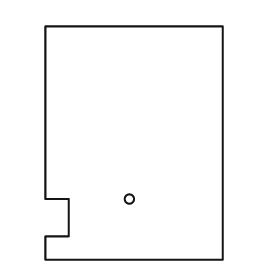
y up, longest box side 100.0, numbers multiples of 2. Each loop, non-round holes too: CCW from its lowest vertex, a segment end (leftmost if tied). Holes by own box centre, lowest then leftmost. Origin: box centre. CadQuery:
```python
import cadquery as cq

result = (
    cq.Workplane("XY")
    .moveTo(-38.0, -50.0)
    .lineTo(38.0, -50.0)
    .lineTo(38.0, 50.0)
    .lineTo(-38.0, 50.0)
    .lineTo(-38.0, -24.0)
    .lineTo(-28.0, -24.0)
    .lineTo(-28.0, -40.0)
    .lineTo(-38.0, -40.0)
    .close()
    .moveTo(-2.0, -24.0)
    .circle(2.0)
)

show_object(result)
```